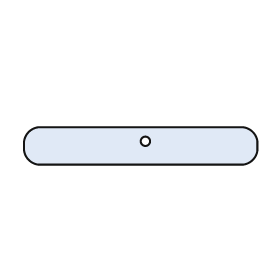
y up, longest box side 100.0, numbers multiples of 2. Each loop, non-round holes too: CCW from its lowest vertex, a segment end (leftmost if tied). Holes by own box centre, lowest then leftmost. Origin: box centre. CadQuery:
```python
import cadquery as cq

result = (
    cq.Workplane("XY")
    .moveTo(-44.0, -8.0)
    .lineTo(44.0, -8.0)
    .threePointArc((48.0, -6.0), (50.0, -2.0))
    .lineTo(50.0, 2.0)
    .threePointArc((48.0, 6.0), (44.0, 8.0))
    .lineTo(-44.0, 8.0)
    .threePointArc((-48.0, 6.0), (-50.0, 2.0))
    .lineTo(-50.0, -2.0)
    .threePointArc((-48.0, -6.0), (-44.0, -8.0))
    .close()
    .moveTo(2.0, 2.0)
    .circle(2.0)
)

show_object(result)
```